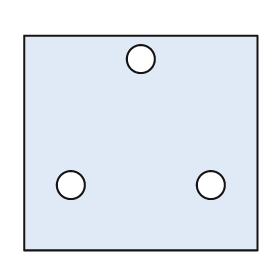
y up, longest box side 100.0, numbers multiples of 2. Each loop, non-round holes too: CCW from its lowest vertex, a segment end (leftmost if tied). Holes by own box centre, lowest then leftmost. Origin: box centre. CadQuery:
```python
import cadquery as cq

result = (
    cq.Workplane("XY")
    .moveTo(-50.0, -46.0)
    .lineTo(50.0, -46.0)
    .lineTo(50.0, 46.0)
    .lineTo(-50.0, 46.0)
    .close()
    .moveTo(-30.0, -18.0)
    .circle(6.0)
    .moveTo(30.0, -18.0)
    .circle(6.0)
    .moveTo(0.0, 36.0)
    .circle(6.0)
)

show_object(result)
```